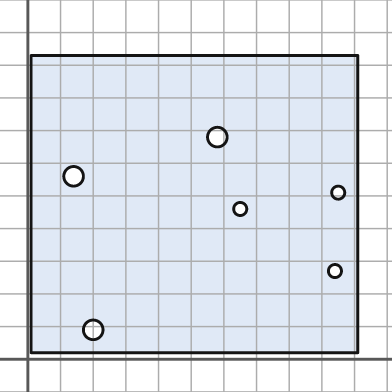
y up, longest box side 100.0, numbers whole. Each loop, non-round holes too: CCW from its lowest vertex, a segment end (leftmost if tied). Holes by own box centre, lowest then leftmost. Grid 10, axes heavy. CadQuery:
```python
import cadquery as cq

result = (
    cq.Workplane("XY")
    .moveTo(1.0, 2.0)
    .lineTo(101.0, 2.0)
    .lineTo(101.0, 93.0)
    .lineTo(1.0, 93.0)
    .close()
    .moveTo(20.0, 9.0)
    .circle(3.0)
    .moveTo(94.0, 27.0)
    .circle(2.0)
    .moveTo(65.0, 46.0)
    .circle(2.0)
    .moveTo(95.0, 51.0)
    .circle(2.0)
    .moveTo(14.0, 56.0)
    .circle(3.0)
    .moveTo(58.0, 68.0)
    .circle(3.0)
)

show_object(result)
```